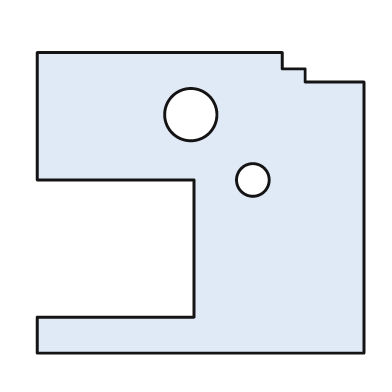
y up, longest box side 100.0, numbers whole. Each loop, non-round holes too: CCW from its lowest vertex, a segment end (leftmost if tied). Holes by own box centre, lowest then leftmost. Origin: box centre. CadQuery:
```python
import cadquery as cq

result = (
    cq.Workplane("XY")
    .moveTo(-50.0, -46.0)
    .lineTo(50.0, -46.0)
    .lineTo(50.0, 37.0)
    .lineTo(32.0, 37.0)
    .lineTo(32.0, 41.0)
    .lineTo(25.0, 41.0)
    .lineTo(25.0, 46.0)
    .lineTo(-50.0, 46.0)
    .lineTo(-50.0, 7.0)
    .lineTo(-2.0, 7.0)
    .lineTo(-2.0, -35.0)
    .lineTo(-50.0, -35.0)
    .close()
    .moveTo(16.0, 7.0)
    .circle(5.0)
    .moveTo(-3.0, 27.0)
    .circle(8.0)
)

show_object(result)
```